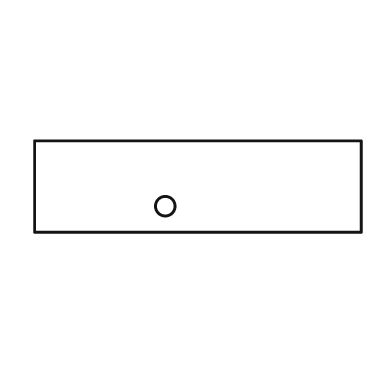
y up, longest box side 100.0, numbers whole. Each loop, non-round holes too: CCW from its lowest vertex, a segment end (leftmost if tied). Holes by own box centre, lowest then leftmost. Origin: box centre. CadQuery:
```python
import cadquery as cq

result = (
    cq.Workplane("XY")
    .moveTo(-50.0, -14.0)
    .lineTo(50.0, -14.0)
    .lineTo(50.0, 14.0)
    .lineTo(-50.0, 14.0)
    .close()
    .moveTo(-10.0, -6.0)
    .circle(3.0)
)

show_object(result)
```